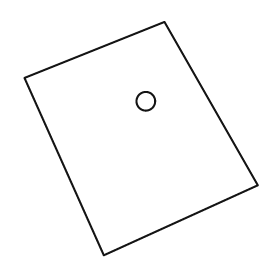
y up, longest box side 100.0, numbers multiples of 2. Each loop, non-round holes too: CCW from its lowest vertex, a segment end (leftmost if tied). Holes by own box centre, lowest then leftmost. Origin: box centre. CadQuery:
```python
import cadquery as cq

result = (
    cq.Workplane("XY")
    .moveTo(-16.0, -50.0)
    .lineTo(50.0, -20.0)
    .lineTo(10.0, 50.0)
    .lineTo(-50.0, 26.0)
    .close()
    .moveTo(2.0, 16.0)
    .circle(4.0)
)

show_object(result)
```